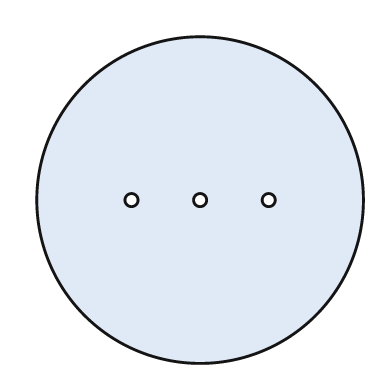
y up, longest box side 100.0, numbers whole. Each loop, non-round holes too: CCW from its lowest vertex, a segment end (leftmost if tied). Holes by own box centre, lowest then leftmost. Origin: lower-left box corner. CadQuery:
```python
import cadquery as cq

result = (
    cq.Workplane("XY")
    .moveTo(50.0, 50.0)
    .circle(50.0)
    .moveTo(29.0, 50.0)
    .circle(2.0)
    .moveTo(50.0, 50.0)
    .circle(2.0)
    .moveTo(71.0, 50.0)
    .circle(2.0)
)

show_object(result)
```